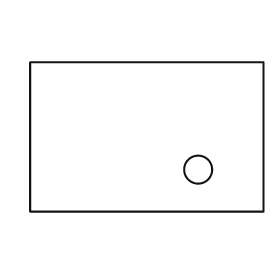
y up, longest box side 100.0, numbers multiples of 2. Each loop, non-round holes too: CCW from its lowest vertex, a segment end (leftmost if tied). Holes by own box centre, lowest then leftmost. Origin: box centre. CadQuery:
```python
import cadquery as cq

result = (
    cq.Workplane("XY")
    .moveTo(-50.0, -32.0)
    .lineTo(50.0, -32.0)
    .lineTo(50.0, 32.0)
    .lineTo(-50.0, 32.0)
    .close()
    .moveTo(22.0, -14.0)
    .circle(6.0)
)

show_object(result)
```